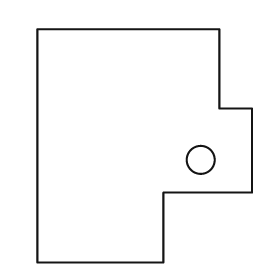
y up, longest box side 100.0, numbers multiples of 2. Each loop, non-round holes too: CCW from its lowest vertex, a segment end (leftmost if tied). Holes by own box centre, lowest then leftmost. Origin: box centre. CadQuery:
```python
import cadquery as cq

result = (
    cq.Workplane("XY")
    .moveTo(-46.0, -50.0)
    .lineTo(8.0, -50.0)
    .lineTo(8.0, -20.0)
    .lineTo(46.0, -20.0)
    .lineTo(46.0, 16.0)
    .lineTo(32.0, 16.0)
    .lineTo(32.0, 50.0)
    .lineTo(-46.0, 50.0)
    .close()
    .moveTo(24.0, -6.0)
    .circle(6.0)
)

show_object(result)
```